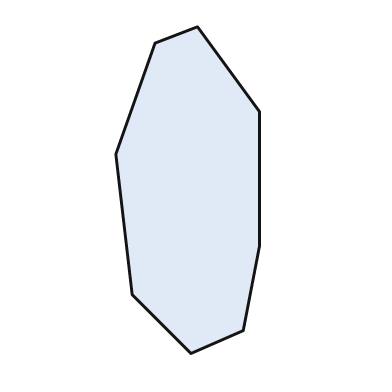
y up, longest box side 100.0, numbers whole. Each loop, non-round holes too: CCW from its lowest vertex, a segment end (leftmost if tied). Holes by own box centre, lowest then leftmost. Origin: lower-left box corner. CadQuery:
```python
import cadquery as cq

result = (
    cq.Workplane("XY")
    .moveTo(23.0, 0.0)
    .lineTo(39.0, 7.0)
    .lineTo(44.0, 33.0)
    .lineTo(44.0, 74.0)
    .lineTo(25.0, 100.0)
    .lineTo(12.0, 95.0)
    .lineTo(0.0, 61.0)
    .lineTo(5.0, 18.0)
    .close()
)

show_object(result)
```